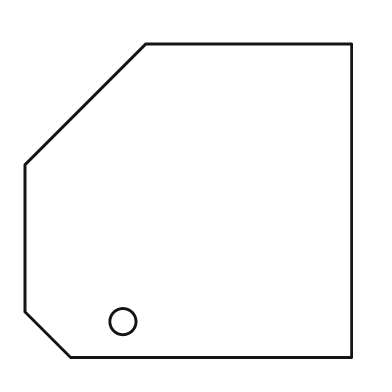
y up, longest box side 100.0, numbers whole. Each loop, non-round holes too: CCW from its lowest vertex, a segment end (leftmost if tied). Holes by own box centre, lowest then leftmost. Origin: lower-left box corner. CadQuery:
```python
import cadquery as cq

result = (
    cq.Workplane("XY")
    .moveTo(14.0, 0.0)
    .lineTo(100.0, 0.0)
    .lineTo(100.0, 96.0)
    .lineTo(37.0, 96.0)
    .lineTo(0.0, 59.0)
    .lineTo(0.0, 14.0)
    .close()
    .moveTo(30.0, 11.0)
    .circle(4.0)
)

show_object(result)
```